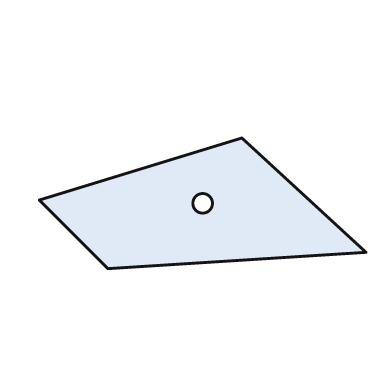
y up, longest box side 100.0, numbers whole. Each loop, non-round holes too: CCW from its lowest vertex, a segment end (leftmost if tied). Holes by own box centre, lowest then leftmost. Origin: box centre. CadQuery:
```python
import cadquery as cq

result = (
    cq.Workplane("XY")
    .moveTo(-29.0, -20.0)
    .lineTo(50.0, -15.0)
    .lineTo(12.0, 20.0)
    .lineTo(-50.0, 1.0)
    .close()
    .moveTo(0.0, 0.0)
    .circle(3.0)
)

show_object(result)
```